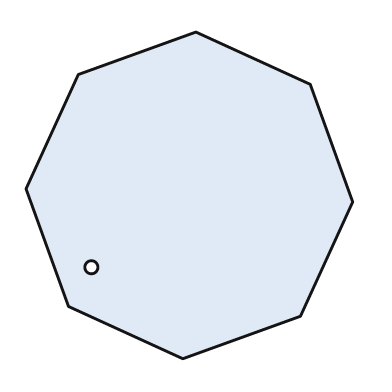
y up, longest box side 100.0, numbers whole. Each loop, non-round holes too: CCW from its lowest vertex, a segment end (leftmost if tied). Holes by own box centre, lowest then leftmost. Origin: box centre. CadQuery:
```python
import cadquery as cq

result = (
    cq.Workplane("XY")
    .moveTo(-2.0, -50.0)
    .lineTo(34.0, -37.0)
    .lineTo(50.0, -2.0)
    .lineTo(37.0, 34.0)
    .lineTo(2.0, 50.0)
    .lineTo(-34.0, 37.0)
    .lineTo(-50.0, 2.0)
    .lineTo(-37.0, -34.0)
    .close()
    .moveTo(-30.0, -22.0)
    .circle(2.0)
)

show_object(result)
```